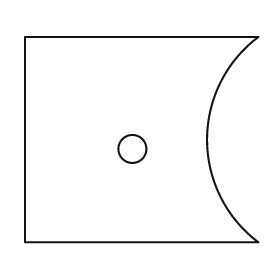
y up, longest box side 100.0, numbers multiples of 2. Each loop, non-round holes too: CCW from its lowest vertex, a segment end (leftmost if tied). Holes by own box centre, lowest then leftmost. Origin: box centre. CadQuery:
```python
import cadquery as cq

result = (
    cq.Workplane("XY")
    .moveTo(-50.0, -44.0)
    .lineTo(50.0, -44.0)
    .threePointArc((28.0, 0.0), (50.0, 44.0))
    .lineTo(-50.0, 44.0)
    .close()
    .moveTo(-4.0, -4.0)
    .circle(6.0)
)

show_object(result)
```